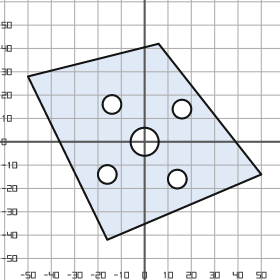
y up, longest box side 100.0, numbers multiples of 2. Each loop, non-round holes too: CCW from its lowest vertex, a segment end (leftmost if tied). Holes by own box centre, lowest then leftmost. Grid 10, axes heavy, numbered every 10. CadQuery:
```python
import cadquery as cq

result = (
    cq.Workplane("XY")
    .moveTo(-16.0, -42.0)
    .lineTo(50.0, -14.0)
    .lineTo(6.0, 42.0)
    .lineTo(-50.0, 28.0)
    .close()
    .moveTo(14.0, -16.0)
    .circle(4.0)
    .moveTo(-16.0, -14.0)
    .circle(4.0)
    .moveTo(0.0, 0.0)
    .circle(6.0)
    .moveTo(16.0, 14.0)
    .circle(4.0)
    .moveTo(-14.0, 16.0)
    .circle(4.0)
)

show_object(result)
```